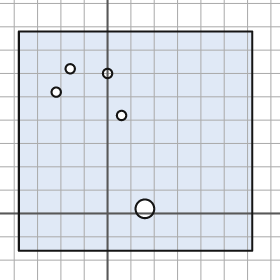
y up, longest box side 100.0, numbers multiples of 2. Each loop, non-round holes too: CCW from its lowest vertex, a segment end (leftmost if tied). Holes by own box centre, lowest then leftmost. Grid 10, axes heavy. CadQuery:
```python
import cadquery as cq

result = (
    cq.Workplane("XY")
    .moveTo(-38.0, -16.0)
    .lineTo(62.0, -16.0)
    .lineTo(62.0, 78.0)
    .lineTo(-38.0, 78.0)
    .close()
    .moveTo(16.0, 2.0)
    .circle(4.0)
    .moveTo(6.0, 42.0)
    .circle(2.0)
    .moveTo(-22.0, 52.0)
    .circle(2.0)
    .moveTo(0.0, 60.0)
    .circle(2.0)
    .moveTo(-16.0, 62.0)
    .circle(2.0)
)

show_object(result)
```